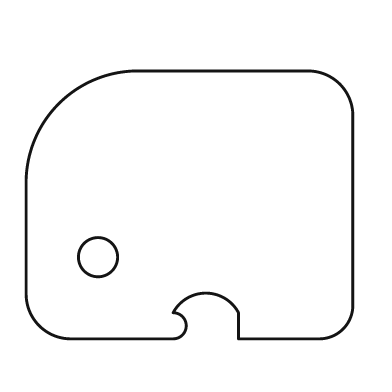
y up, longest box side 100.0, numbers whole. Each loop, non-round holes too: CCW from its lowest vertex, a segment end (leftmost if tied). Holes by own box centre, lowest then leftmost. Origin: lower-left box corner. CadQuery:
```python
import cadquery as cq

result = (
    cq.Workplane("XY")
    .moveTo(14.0, 0.0)
    .lineTo(45.0, 0.0)
    .threePointArc((49.0, 4.0), (45.0, 8.0))
    .threePointArc((55.0, 14.0), (65.0, 8.0))
    .lineTo(65.0, 0.0)
    .lineTo(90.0, 0.0)
    .threePointArc((97.0, 3.0), (100.0, 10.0))
    .lineTo(100.0, 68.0)
    .threePointArc((96.0, 78.0), (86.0, 82.0))
    .lineTo(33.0, 82.0)
    .threePointArc((10.0, 72.0), (0.0, 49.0))
    .lineTo(0.0, 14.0)
    .threePointArc((4.0, 4.0), (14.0, 0.0))
    .close()
    .moveTo(22.0, 25.0)
    .circle(6.0)
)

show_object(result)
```